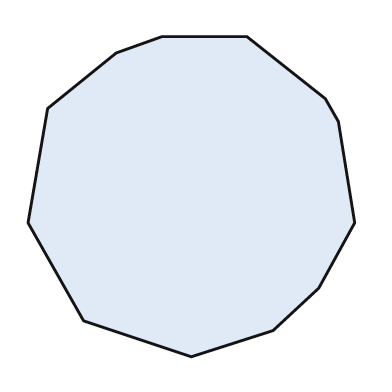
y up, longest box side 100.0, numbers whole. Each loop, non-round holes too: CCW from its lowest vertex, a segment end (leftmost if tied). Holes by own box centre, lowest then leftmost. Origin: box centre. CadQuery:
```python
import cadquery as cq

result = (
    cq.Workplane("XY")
    .moveTo(0.0, -49.0)
    .lineTo(25.0, -41.0)
    .lineTo(39.0, -28.0)
    .lineTo(50.0, -8.0)
    .lineTo(45.0, 23.0)
    .lineTo(41.0, 30.0)
    .lineTo(17.0, 49.0)
    .lineTo(-9.0, 49.0)
    .lineTo(-23.0, 44.0)
    .lineTo(-44.0, 27.0)
    .lineTo(-50.0, -8.0)
    .lineTo(-33.0, -38.0)
    .close()
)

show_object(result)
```